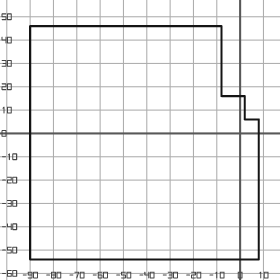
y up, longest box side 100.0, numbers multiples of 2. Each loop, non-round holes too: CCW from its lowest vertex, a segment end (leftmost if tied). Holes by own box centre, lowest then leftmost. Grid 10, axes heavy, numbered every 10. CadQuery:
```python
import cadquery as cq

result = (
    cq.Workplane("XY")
    .moveTo(-90.0, -54.0)
    .lineTo(8.0, -54.0)
    .lineTo(8.0, 6.0)
    .lineTo(2.0, 6.0)
    .lineTo(2.0, 16.0)
    .lineTo(-8.0, 16.0)
    .lineTo(-8.0, 46.0)
    .lineTo(-90.0, 46.0)
    .close()
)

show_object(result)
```